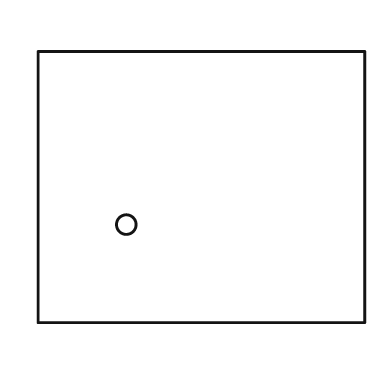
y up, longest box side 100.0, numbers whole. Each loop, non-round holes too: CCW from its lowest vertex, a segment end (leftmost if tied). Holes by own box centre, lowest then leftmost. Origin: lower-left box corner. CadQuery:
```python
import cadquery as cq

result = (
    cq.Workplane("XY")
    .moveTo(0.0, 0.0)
    .lineTo(100.0, 0.0)
    .lineTo(100.0, 83.0)
    .lineTo(0.0, 83.0)
    .close()
    .moveTo(27.0, 30.0)
    .circle(3.0)
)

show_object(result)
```